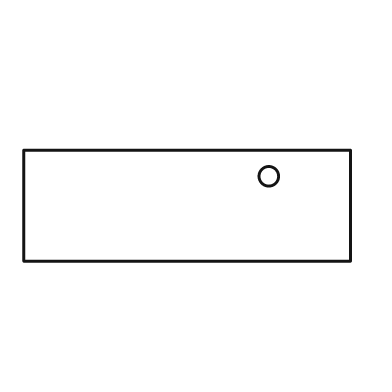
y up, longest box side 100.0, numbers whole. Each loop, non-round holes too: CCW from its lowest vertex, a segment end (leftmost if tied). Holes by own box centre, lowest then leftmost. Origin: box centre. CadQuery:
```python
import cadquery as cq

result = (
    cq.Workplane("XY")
    .moveTo(-50.0, -17.0)
    .lineTo(50.0, -17.0)
    .lineTo(50.0, 17.0)
    .lineTo(-50.0, 17.0)
    .close()
    .moveTo(25.0, 9.0)
    .circle(3.0)
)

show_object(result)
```